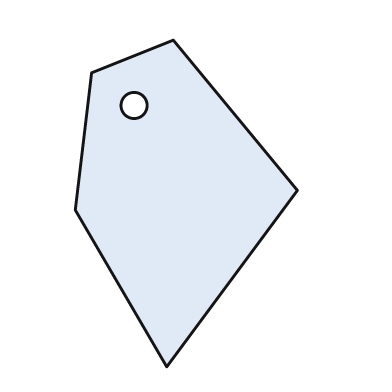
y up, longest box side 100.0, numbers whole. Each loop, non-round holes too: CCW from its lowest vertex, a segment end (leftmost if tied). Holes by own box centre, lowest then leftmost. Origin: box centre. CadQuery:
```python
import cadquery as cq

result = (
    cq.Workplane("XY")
    .moveTo(-6.0, -50.0)
    .lineTo(34.0, 4.0)
    .lineTo(-4.0, 50.0)
    .lineTo(-29.0, 40.0)
    .lineTo(-34.0, -2.0)
    .close()
    .moveTo(-16.0, 30.0)
    .circle(4.0)
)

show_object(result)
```